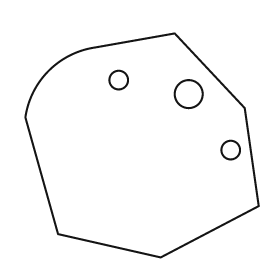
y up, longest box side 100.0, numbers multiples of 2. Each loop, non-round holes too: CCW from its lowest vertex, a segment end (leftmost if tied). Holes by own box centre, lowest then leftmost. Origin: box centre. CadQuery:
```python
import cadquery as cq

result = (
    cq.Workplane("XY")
    .moveTo(8.0, -48.0)
    .lineTo(50.0, -26.0)
    .lineTo(44.0, 16.0)
    .lineTo(14.0, 48.0)
    .lineTo(-20.0, 42.0)
    .threePointArc((-40.0, 32.0), (-50.0, 12.0))
    .lineTo(-36.0, -38.0)
    .close()
    .moveTo(38.0, -2.0)
    .circle(4.0)
    .moveTo(20.0, 22.0)
    .circle(6.0)
    .moveTo(-10.0, 28.0)
    .circle(4.0)
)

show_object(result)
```